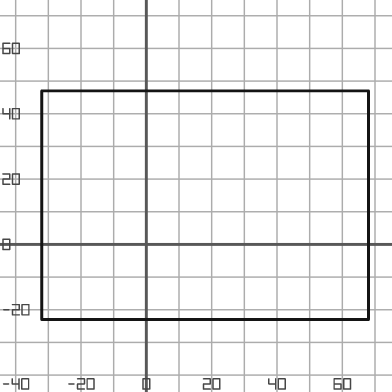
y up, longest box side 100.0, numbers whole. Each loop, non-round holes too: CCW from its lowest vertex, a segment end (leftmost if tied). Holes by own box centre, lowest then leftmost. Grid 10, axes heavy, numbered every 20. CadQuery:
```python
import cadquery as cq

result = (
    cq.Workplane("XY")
    .moveTo(-32.0, -23.0)
    .lineTo(68.0, -23.0)
    .lineTo(68.0, 47.0)
    .lineTo(-32.0, 47.0)
    .close()
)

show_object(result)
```